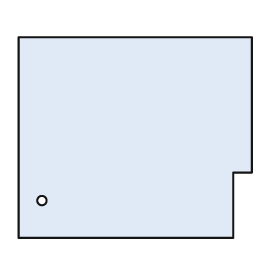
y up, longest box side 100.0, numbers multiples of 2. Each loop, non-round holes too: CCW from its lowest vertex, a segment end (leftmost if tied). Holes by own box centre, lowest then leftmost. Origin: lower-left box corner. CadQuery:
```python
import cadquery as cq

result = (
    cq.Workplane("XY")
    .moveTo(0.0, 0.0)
    .lineTo(92.0, 0.0)
    .lineTo(92.0, 28.0)
    .lineTo(100.0, 28.0)
    .lineTo(100.0, 86.0)
    .lineTo(0.0, 86.0)
    .close()
    .moveTo(10.0, 16.0)
    .circle(2.0)
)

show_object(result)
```